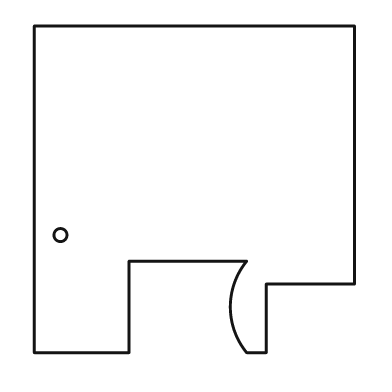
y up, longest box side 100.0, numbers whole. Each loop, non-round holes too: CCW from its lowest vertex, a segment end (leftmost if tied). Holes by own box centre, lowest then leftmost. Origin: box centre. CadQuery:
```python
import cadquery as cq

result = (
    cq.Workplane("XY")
    .moveTo(-49.0, -50.0)
    .lineTo(-20.0, -50.0)
    .lineTo(-20.0, -22.0)
    .lineTo(16.0, -22.0)
    .threePointArc((11.0, -36.0), (16.0, -50.0))
    .lineTo(22.0, -50.0)
    .lineTo(22.0, -29.0)
    .lineTo(49.0, -29.0)
    .lineTo(49.0, 50.0)
    .lineTo(-49.0, 50.0)
    .close()
    .moveTo(-41.0, -14.0)
    .circle(2.0)
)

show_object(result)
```